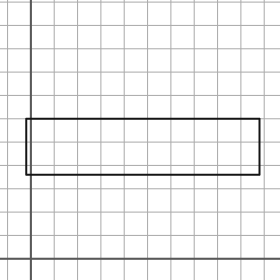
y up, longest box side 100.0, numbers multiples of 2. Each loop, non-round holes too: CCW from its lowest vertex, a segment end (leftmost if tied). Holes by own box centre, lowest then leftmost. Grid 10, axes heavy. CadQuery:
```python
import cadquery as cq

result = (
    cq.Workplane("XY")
    .moveTo(-2.0, 36.0)
    .lineTo(98.0, 36.0)
    .lineTo(98.0, 60.0)
    .lineTo(-2.0, 60.0)
    .close()
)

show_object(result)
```